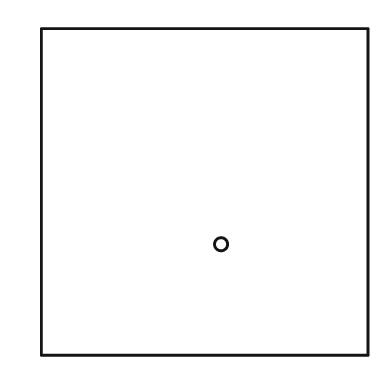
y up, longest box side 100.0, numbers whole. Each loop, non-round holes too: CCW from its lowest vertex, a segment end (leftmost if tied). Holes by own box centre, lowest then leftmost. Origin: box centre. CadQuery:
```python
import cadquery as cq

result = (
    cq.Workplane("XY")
    .moveTo(-50.0, -50.0)
    .lineTo(50.0, -50.0)
    .lineTo(50.0, 50.0)
    .lineTo(-50.0, 50.0)
    .close()
    .moveTo(5.0, -16.0)
    .circle(2.0)
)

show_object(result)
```